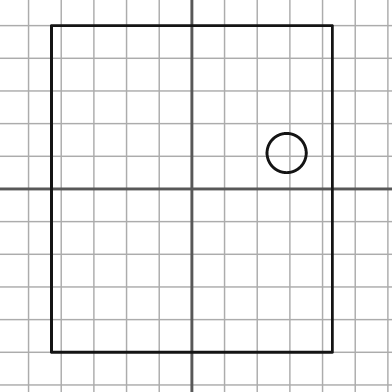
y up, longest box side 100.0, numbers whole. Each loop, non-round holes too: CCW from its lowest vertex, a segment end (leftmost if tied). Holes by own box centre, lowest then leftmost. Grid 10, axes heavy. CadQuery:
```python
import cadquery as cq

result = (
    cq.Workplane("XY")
    .moveTo(-43.0, -50.0)
    .lineTo(43.0, -50.0)
    .lineTo(43.0, 50.0)
    .lineTo(-43.0, 50.0)
    .close()
    .moveTo(29.0, 11.0)
    .circle(6.0)
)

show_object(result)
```